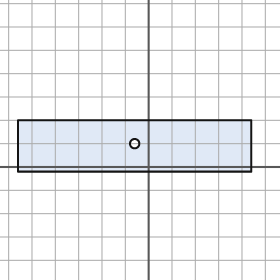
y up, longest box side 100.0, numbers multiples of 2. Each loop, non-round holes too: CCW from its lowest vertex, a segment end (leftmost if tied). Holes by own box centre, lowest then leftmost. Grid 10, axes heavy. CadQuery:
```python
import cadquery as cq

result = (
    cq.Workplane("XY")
    .moveTo(-56.0, -2.0)
    .lineTo(44.0, -2.0)
    .lineTo(44.0, 20.0)
    .lineTo(-56.0, 20.0)
    .close()
    .moveTo(-6.0, 10.0)
    .circle(2.0)
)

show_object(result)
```